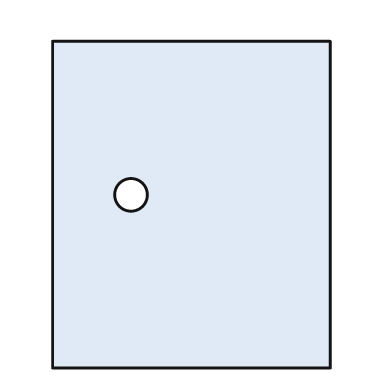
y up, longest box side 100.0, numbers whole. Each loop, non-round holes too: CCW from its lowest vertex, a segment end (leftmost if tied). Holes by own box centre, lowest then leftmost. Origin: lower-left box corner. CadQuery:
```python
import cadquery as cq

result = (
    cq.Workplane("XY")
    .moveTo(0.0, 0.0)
    .lineTo(85.0, 0.0)
    .lineTo(85.0, 100.0)
    .lineTo(0.0, 100.0)
    .close()
    .moveTo(24.0, 53.0)
    .circle(5.0)
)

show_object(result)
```